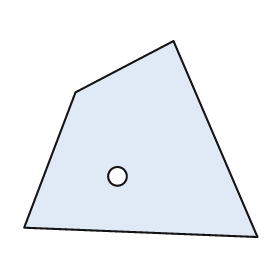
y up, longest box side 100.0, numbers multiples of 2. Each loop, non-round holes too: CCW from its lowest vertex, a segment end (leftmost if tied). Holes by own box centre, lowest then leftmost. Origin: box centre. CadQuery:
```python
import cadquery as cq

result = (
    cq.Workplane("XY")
    .moveTo(50.0, -42.0)
    .lineTo(14.0, 42.0)
    .lineTo(-28.0, 20.0)
    .lineTo(-50.0, -38.0)
    .close()
    .moveTo(-10.0, -16.0)
    .circle(4.0)
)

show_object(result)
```